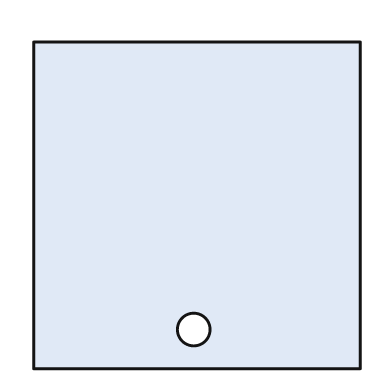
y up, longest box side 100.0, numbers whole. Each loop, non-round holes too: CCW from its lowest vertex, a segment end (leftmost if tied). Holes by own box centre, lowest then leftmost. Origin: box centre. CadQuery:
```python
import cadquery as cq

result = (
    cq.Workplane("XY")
    .moveTo(-50.0, -50.0)
    .lineTo(50.0, -50.0)
    .lineTo(50.0, 50.0)
    .lineTo(-50.0, 50.0)
    .close()
    .moveTo(-1.0, -38.0)
    .circle(5.0)
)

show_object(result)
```